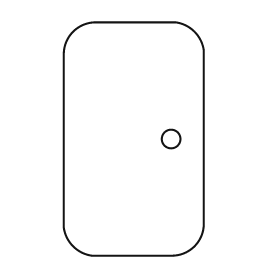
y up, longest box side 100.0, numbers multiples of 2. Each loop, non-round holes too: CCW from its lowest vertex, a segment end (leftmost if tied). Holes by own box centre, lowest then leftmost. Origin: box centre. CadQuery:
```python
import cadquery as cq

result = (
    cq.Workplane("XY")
    .moveTo(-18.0, -50.0)
    .lineTo(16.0, -50.0)
    .threePointArc((26.0, -46.0), (30.0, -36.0))
    .lineTo(30.0, 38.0)
    .threePointArc((26.0, 46.0), (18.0, 50.0))
    .lineTo(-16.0, 50.0)
    .threePointArc((-26.0, 46.0), (-30.0, 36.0))
    .lineTo(-30.0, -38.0)
    .threePointArc((-26.0, -46.0), (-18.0, -50.0))
    .close()
    .moveTo(16.0, 0.0)
    .circle(4.0)
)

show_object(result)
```